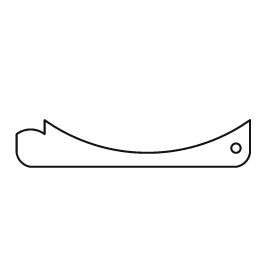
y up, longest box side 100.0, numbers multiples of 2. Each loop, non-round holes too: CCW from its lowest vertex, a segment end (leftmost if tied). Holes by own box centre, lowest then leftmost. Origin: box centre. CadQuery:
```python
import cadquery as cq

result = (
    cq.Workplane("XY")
    .moveTo(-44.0, -10.0)
    .lineTo(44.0, -10.0)
    .threePointArc((48.0, -8.0), (50.0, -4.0))
    .lineTo(50.0, 10.0)
    .threePointArc((6.0, -4.0), (-38.0, 10.0))
    .lineTo(-38.0, 4.0)
    .threePointArc((-44.0, 6.0), (-50.0, 4.0))
    .lineTo(-50.0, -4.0)
    .threePointArc((-48.0, -8.0), (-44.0, -10.0))
    .close()
    .moveTo(44.0, -2.0)
    .circle(2.0)
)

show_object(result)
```